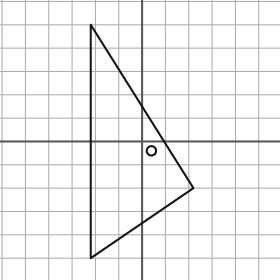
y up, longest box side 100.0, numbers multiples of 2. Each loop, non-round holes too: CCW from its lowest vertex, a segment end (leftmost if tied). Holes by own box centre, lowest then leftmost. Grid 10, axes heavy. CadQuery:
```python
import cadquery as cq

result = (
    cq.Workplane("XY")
    .moveTo(-22.0, -50.0)
    .lineTo(22.0, -20.0)
    .lineTo(-22.0, 50.0)
    .close()
    .moveTo(4.0, -4.0)
    .circle(2.0)
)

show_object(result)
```